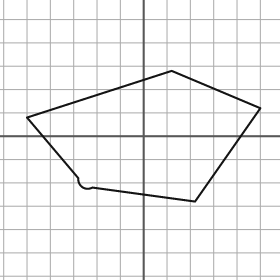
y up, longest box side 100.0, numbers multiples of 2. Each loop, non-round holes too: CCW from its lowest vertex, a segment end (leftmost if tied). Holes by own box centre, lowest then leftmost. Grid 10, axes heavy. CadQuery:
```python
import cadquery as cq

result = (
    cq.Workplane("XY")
    .moveTo(22.0, -28.0)
    .lineTo(50.0, 12.0)
    .lineTo(12.0, 28.0)
    .lineTo(-50.0, 8.0)
    .lineTo(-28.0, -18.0)
    .threePointArc((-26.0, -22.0), (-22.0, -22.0))
    .close()
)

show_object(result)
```